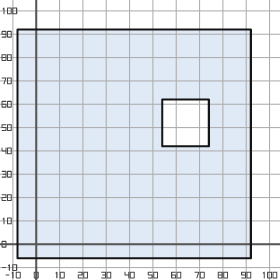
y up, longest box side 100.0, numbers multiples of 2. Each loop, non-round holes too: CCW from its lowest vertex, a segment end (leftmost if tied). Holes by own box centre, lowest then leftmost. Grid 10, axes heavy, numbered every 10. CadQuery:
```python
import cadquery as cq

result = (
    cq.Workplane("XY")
    .moveTo(-8.0, -6.0)
    .lineTo(92.0, -6.0)
    .lineTo(92.0, 92.0)
    .lineTo(-8.0, 92.0)
    .close()
    .moveTo(54.0, 42.0)
    .lineTo(74.0, 42.0)
    .lineTo(74.0, 62.0)
    .lineTo(54.0, 62.0)
    .close()
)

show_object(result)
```